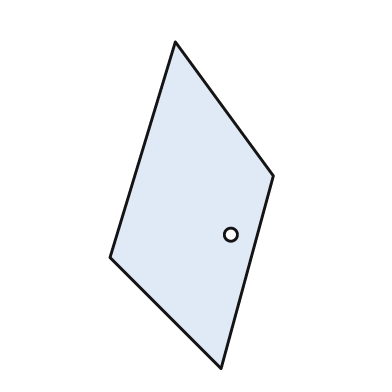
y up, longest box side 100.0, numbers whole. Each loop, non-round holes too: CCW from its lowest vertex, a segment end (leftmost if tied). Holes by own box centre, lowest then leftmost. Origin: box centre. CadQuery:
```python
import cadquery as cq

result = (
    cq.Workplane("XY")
    .moveTo(9.0, -50.0)
    .lineTo(25.0, 9.0)
    .lineTo(-5.0, 50.0)
    .lineTo(-25.0, -16.0)
    .close()
    .moveTo(12.0, -9.0)
    .circle(2.0)
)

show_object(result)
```